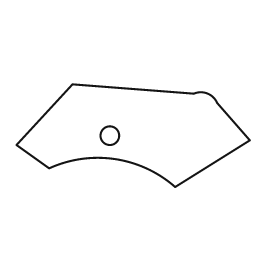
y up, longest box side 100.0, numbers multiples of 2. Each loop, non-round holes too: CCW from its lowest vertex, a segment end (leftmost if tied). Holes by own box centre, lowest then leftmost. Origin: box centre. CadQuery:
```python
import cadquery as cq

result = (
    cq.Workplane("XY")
    .moveTo(18.0, -22.0)
    .lineTo(50.0, -2.0)
    .lineTo(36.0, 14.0)
    .threePointArc((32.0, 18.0), (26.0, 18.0))
    .lineTo(-26.0, 22.0)
    .lineTo(-50.0, -4.0)
    .lineTo(-36.0, -14.0)
    .threePointArc((-8.0, -10.0), (18.0, -22.0))
    .close()
    .moveTo(-10.0, 0.0)
    .circle(4.0)
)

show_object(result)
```